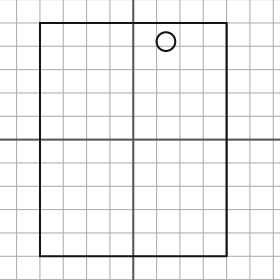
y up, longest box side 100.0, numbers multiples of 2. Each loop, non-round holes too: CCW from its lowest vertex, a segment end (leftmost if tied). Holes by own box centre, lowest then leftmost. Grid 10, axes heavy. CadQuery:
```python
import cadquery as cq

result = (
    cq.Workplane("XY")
    .moveTo(-40.0, -50.0)
    .lineTo(40.0, -50.0)
    .lineTo(40.0, 50.0)
    .lineTo(-40.0, 50.0)
    .close()
    .moveTo(14.0, 42.0)
    .circle(4.0)
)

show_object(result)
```